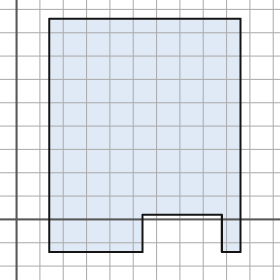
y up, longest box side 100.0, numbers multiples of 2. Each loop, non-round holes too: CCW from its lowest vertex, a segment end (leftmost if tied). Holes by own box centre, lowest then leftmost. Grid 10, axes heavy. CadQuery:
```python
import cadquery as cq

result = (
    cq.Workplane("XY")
    .moveTo(14.0, -14.0)
    .lineTo(54.0, -14.0)
    .lineTo(54.0, 2.0)
    .lineTo(88.0, 2.0)
    .lineTo(88.0, -14.0)
    .lineTo(96.0, -14.0)
    .lineTo(96.0, 86.0)
    .lineTo(14.0, 86.0)
    .close()
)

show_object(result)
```